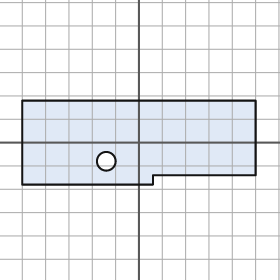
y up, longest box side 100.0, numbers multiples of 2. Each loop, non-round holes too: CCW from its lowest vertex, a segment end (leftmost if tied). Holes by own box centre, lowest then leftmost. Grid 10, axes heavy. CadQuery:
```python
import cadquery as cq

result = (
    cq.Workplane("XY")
    .moveTo(-50.0, -18.0)
    .lineTo(6.0, -18.0)
    .lineTo(6.0, -14.0)
    .lineTo(50.0, -14.0)
    .lineTo(50.0, 18.0)
    .lineTo(-50.0, 18.0)
    .close()
    .moveTo(-14.0, -8.0)
    .circle(4.0)
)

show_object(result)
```